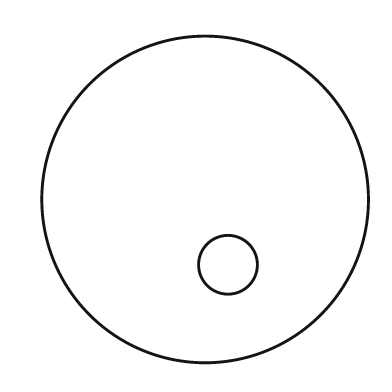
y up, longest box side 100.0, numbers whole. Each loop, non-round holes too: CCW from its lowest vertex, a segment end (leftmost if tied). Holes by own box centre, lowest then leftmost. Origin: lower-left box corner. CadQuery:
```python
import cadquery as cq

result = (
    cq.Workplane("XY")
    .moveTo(50.0, 50.0)
    .circle(50.0)
    .moveTo(57.0, 30.0)
    .circle(9.0)
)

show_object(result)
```